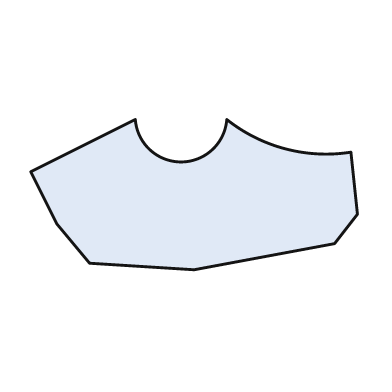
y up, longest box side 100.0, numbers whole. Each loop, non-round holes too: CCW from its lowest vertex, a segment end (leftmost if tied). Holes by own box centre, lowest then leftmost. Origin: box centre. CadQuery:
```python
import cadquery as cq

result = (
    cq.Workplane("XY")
    .moveTo(0.0, -23.0)
    .lineTo(43.0, -15.0)
    .lineTo(50.0, -6.0)
    .lineTo(48.0, 13.0)
    .threePointArc((28.0, 14.0), (10.0, 23.0))
    .threePointArc((-4.0, 10.0), (-18.0, 23.0))
    .lineTo(-50.0, 7.0)
    .lineTo(-42.0, -9.0)
    .lineTo(-32.0, -21.0)
    .close()
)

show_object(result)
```